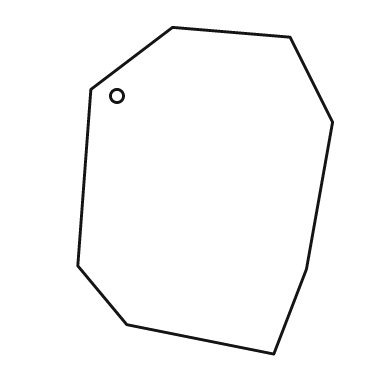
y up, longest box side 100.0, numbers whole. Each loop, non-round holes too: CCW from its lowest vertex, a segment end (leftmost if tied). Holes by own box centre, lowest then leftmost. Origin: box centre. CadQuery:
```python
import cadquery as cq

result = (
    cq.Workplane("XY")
    .moveTo(21.0, -50.0)
    .lineTo(31.0, -24.0)
    .lineTo(39.0, 21.0)
    .lineTo(26.0, 47.0)
    .lineTo(-10.0, 50.0)
    .lineTo(-35.0, 31.0)
    .lineTo(-39.0, -23.0)
    .lineTo(-24.0, -41.0)
    .close()
    .moveTo(-27.0, 29.0)
    .circle(2.0)
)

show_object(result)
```